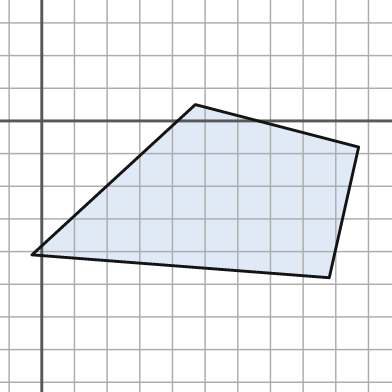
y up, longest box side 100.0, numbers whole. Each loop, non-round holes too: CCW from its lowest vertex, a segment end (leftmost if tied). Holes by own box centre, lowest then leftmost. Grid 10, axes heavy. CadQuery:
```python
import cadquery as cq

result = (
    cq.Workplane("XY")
    .moveTo(88.0, -48.0)
    .lineTo(97.0, -8.0)
    .lineTo(47.0, 5.0)
    .lineTo(-3.0, -41.0)
    .close()
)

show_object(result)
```